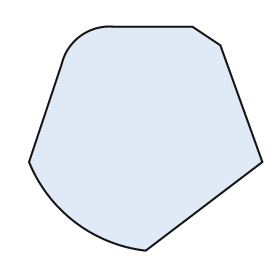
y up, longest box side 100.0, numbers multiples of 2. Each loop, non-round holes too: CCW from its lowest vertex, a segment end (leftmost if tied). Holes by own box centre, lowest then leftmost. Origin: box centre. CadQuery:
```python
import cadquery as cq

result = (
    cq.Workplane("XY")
    .moveTo(0.0, -48.0)
    .lineTo(50.0, -10.0)
    .lineTo(32.0, 40.0)
    .lineTo(20.0, 48.0)
    .lineTo(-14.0, 48.0)
    .threePointArc((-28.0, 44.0), (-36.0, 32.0))
    .lineTo(-50.0, -10.0)
    .threePointArc((-30.0, -36.0), (0.0, -48.0))
    .close()
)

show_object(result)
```